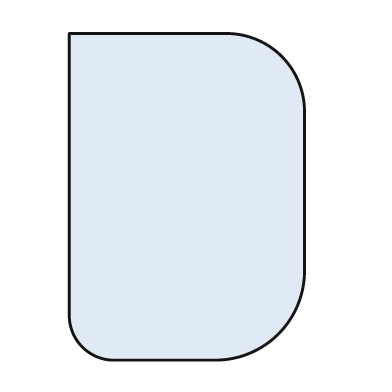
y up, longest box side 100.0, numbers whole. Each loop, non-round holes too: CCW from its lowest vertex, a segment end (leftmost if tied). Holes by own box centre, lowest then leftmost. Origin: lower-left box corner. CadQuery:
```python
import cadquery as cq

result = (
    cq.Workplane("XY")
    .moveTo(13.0, 0.0)
    .lineTo(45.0, 0.0)
    .threePointArc((64.0, 8.0), (72.0, 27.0))
    .lineTo(72.0, 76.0)
    .threePointArc((65.0, 93.0), (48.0, 100.0))
    .lineTo(0.0, 100.0)
    .lineTo(0.0, 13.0)
    .threePointArc((4.0, 4.0), (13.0, 0.0))
    .close()
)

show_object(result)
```